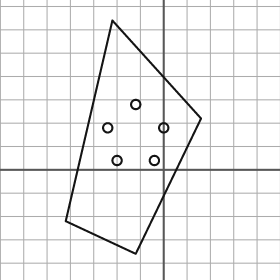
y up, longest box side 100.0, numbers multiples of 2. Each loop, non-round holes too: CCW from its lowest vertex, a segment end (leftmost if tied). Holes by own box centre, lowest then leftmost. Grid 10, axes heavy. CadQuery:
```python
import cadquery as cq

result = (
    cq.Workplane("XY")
    .moveTo(-12.0, -36.0)
    .lineTo(16.0, 22.0)
    .lineTo(-22.0, 64.0)
    .lineTo(-42.0, -22.0)
    .close()
    .moveTo(-20.0, 4.0)
    .circle(2.0)
    .moveTo(-4.0, 4.0)
    .circle(2.0)
    .moveTo(-24.0, 18.0)
    .circle(2.0)
    .moveTo(0.0, 18.0)
    .circle(2.0)
    .moveTo(-12.0, 28.0)
    .circle(2.0)
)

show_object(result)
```